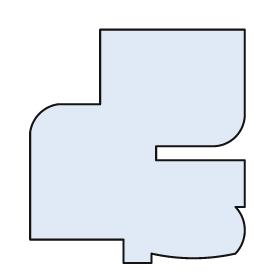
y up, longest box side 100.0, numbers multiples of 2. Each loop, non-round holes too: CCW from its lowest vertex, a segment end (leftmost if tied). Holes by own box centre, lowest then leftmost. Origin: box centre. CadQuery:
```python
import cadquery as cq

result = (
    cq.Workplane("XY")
    .moveTo(-6.0, -50.0)
    .lineTo(6.0, -50.0)
    .lineTo(6.0, -46.0)
    .threePointArc((24.0, -48.0), (42.0, -46.0))
    .threePointArc((46.0, -36.0), (42.0, -26.0))
    .lineTo(46.0, -26.0)
    .lineTo(46.0, -6.0)
    .lineTo(8.0, -6.0)
    .lineTo(8.0, 0.0)
    .lineTo(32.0, 0.0)
    .threePointArc((42.0, 4.0), (46.0, 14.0))
    .lineTo(46.0, 50.0)
    .lineTo(-16.0, 50.0)
    .lineTo(-16.0, 18.0)
    .lineTo(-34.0, 18.0)
    .threePointArc((-42.0, 14.0), (-46.0, 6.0))
    .lineTo(-46.0, -40.0)
    .lineTo(-6.0, -40.0)
    .close()
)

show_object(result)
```